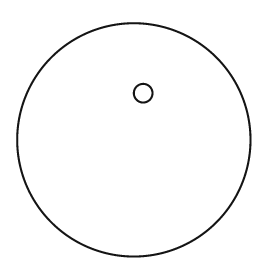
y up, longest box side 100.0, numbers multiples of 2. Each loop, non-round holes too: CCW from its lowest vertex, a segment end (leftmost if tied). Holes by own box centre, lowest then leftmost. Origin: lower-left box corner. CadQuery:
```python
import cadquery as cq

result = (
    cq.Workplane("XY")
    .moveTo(50.0, 50.0)
    .circle(50.0)
    .moveTo(54.0, 70.0)
    .circle(4.0)
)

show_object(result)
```